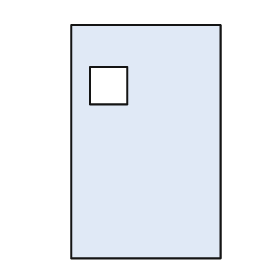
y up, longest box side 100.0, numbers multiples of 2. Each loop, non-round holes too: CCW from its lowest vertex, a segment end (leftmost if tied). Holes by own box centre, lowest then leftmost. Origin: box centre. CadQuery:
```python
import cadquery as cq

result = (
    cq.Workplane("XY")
    .moveTo(-32.0, -50.0)
    .lineTo(32.0, -50.0)
    .lineTo(32.0, 50.0)
    .lineTo(-32.0, 50.0)
    .close()
    .moveTo(-24.0, 16.0)
    .lineTo(-8.0, 16.0)
    .lineTo(-8.0, 32.0)
    .lineTo(-24.0, 32.0)
    .close()
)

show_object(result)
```